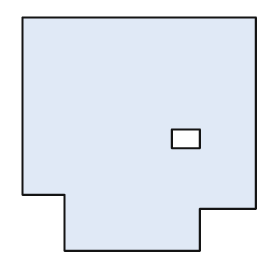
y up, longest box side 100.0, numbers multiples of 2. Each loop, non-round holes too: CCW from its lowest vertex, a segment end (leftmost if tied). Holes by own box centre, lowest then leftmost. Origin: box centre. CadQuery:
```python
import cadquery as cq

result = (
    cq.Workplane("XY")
    .moveTo(-32.0, -50.0)
    .lineTo(26.0, -50.0)
    .lineTo(26.0, -32.0)
    .lineTo(50.0, -32.0)
    .lineTo(50.0, 50.0)
    .lineTo(-50.0, 50.0)
    .lineTo(-50.0, -26.0)
    .lineTo(-32.0, -26.0)
    .close()
    .moveTo(14.0, -6.0)
    .lineTo(26.0, -6.0)
    .lineTo(26.0, 2.0)
    .lineTo(14.0, 2.0)
    .close()
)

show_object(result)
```